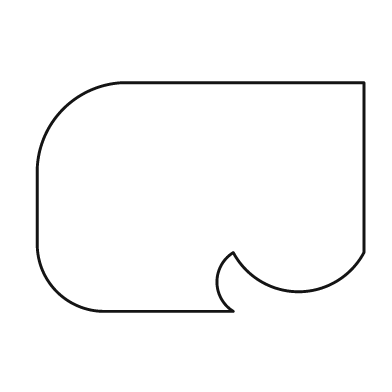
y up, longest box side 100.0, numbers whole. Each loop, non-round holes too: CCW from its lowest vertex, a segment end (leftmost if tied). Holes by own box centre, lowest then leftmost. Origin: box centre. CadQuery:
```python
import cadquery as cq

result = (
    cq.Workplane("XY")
    .moveTo(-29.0, -35.0)
    .lineTo(10.0, -35.0)
    .threePointArc((5.0, -26.0), (10.0, -17.0))
    .threePointArc((30.0, -29.0), (50.0, -17.0))
    .lineTo(50.0, 35.0)
    .lineTo(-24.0, 35.0)
    .threePointArc((-42.0, 27.0), (-50.0, 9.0))
    .lineTo(-50.0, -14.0)
    .threePointArc((-44.0, -29.0), (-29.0, -35.0))
    .close()
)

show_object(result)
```